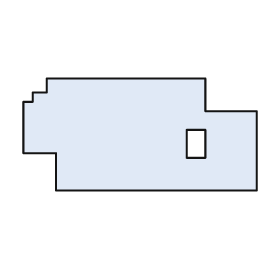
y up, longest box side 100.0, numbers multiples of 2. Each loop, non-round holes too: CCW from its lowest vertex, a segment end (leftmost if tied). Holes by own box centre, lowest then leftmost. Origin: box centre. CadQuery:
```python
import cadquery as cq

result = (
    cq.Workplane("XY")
    .moveTo(-36.0, -24.0)
    .lineTo(50.0, -24.0)
    .lineTo(50.0, 10.0)
    .lineTo(28.0, 10.0)
    .lineTo(28.0, 24.0)
    .lineTo(-40.0, 24.0)
    .lineTo(-40.0, 18.0)
    .lineTo(-46.0, 18.0)
    .lineTo(-46.0, 14.0)
    .lineTo(-50.0, 14.0)
    .lineTo(-50.0, -8.0)
    .lineTo(-36.0, -8.0)
    .close()
    .moveTo(20.0, -10.0)
    .lineTo(28.0, -10.0)
    .lineTo(28.0, 2.0)
    .lineTo(20.0, 2.0)
    .close()
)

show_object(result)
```